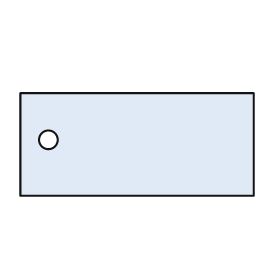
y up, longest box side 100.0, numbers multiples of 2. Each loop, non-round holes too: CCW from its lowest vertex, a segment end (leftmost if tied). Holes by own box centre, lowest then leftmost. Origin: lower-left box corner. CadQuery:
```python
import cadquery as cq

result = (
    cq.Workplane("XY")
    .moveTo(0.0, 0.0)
    .lineTo(100.0, 0.0)
    .lineTo(100.0, 44.0)
    .lineTo(0.0, 44.0)
    .close()
    .moveTo(12.0, 24.0)
    .circle(4.0)
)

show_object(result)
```